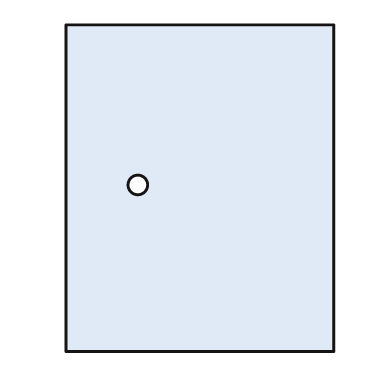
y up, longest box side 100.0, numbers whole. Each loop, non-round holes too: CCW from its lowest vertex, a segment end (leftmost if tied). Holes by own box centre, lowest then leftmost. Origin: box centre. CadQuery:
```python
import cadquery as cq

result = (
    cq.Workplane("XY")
    .moveTo(-41.0, -50.0)
    .lineTo(41.0, -50.0)
    .lineTo(41.0, 50.0)
    .lineTo(-41.0, 50.0)
    .close()
    .moveTo(-19.0, 1.0)
    .circle(3.0)
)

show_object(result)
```